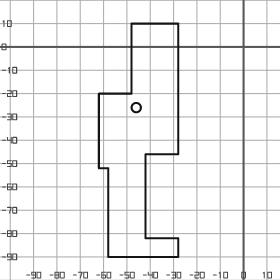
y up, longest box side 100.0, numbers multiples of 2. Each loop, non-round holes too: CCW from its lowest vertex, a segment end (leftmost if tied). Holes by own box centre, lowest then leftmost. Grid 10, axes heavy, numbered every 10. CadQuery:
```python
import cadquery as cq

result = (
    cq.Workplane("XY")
    .moveTo(-58.0, -90.0)
    .lineTo(-28.0, -90.0)
    .lineTo(-28.0, -82.0)
    .lineTo(-42.0, -82.0)
    .lineTo(-42.0, -46.0)
    .lineTo(-28.0, -46.0)
    .lineTo(-28.0, 10.0)
    .lineTo(-48.0, 10.0)
    .lineTo(-48.0, -20.0)
    .lineTo(-62.0, -20.0)
    .lineTo(-62.0, -52.0)
    .lineTo(-58.0, -52.0)
    .close()
    .moveTo(-46.0, -26.0)
    .circle(2.0)
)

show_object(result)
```